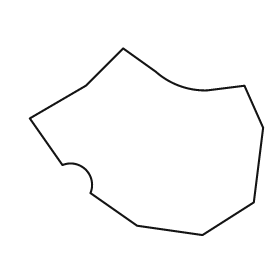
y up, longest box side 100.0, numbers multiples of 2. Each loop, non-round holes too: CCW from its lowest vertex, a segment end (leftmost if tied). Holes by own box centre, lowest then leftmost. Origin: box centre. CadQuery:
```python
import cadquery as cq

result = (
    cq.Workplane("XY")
    .moveTo(24.0, -40.0)
    .lineTo(46.0, -26.0)
    .lineTo(50.0, 6.0)
    .lineTo(42.0, 24.0)
    .lineTo(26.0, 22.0)
    .threePointArc((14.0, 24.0), (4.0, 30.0))
    .lineTo(-10.0, 40.0)
    .lineTo(-26.0, 24.0)
    .lineTo(-50.0, 10.0)
    .lineTo(-36.0, -10.0)
    .threePointArc((-26.0, -12.0), (-24.0, -22.0))
    .lineTo(-4.0, -36.0)
    .close()
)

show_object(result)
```